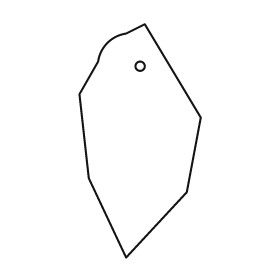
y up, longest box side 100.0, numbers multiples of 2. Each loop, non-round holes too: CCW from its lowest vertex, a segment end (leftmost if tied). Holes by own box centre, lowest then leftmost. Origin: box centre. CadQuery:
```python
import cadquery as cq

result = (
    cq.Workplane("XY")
    .moveTo(-6.0, -50.0)
    .lineTo(20.0, -22.0)
    .lineTo(26.0, 10.0)
    .lineTo(2.0, 50.0)
    .lineTo(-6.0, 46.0)
    .threePointArc((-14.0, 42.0), (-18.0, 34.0))
    .lineTo(-26.0, 20.0)
    .lineTo(-22.0, -16.0)
    .close()
    .moveTo(0.0, 32.0)
    .circle(2.0)
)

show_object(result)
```